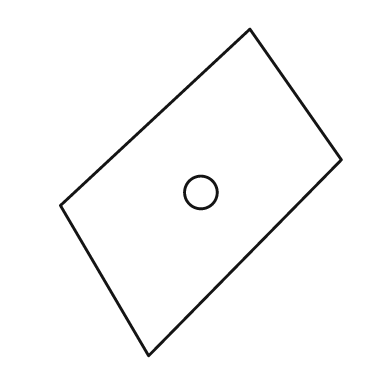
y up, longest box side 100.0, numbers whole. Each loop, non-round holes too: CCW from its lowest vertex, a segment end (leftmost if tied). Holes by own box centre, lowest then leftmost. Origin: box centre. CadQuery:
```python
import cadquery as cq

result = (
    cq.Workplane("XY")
    .moveTo(-16.0, -50.0)
    .lineTo(43.0, 10.0)
    .lineTo(15.0, 50.0)
    .lineTo(-43.0, -4.0)
    .close()
    .moveTo(0.0, 0.0)
    .circle(5.0)
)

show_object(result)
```